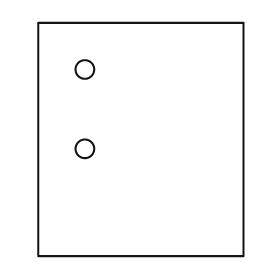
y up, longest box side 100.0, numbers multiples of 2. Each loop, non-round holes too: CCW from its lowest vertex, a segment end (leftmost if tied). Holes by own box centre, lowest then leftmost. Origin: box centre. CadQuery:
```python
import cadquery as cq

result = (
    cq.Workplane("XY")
    .moveTo(-44.0, -50.0)
    .lineTo(44.0, -50.0)
    .lineTo(44.0, 50.0)
    .lineTo(-44.0, 50.0)
    .close()
    .moveTo(-24.0, -4.0)
    .circle(4.0)
    .moveTo(-24.0, 30.0)
    .circle(4.0)
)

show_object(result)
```